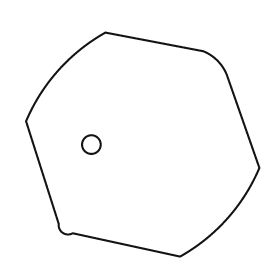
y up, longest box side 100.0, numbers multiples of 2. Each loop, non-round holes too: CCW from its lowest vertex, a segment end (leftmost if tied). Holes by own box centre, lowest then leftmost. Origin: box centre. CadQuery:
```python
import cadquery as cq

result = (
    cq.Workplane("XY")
    .moveTo(16.0, -48.0)
    .threePointArc((36.0, -32.0), (50.0, -10.0))
    .lineTo(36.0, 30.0)
    .threePointArc((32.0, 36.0), (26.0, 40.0))
    .lineTo(-16.0, 48.0)
    .threePointArc((-36.0, 32.0), (-50.0, 10.0))
    .lineTo(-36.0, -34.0)
    .threePointArc((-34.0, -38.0), (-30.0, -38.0))
    .close()
    .moveTo(-22.0, 0.0)
    .circle(4.0)
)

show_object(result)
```